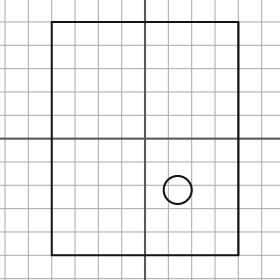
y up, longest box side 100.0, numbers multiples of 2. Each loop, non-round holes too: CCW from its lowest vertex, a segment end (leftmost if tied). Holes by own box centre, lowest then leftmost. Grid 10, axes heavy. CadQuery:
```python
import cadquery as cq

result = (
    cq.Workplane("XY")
    .moveTo(-40.0, -50.0)
    .lineTo(40.0, -50.0)
    .lineTo(40.0, 50.0)
    .lineTo(-40.0, 50.0)
    .close()
    .moveTo(14.0, -22.0)
    .circle(6.0)
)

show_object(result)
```